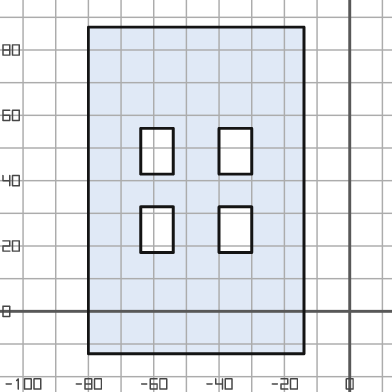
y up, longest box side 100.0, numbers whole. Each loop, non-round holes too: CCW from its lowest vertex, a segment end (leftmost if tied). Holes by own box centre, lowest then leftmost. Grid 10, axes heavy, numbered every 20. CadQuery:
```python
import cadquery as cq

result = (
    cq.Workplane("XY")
    .moveTo(-80.0, -13.0)
    .lineTo(-14.0, -13.0)
    .lineTo(-14.0, 87.0)
    .lineTo(-80.0, 87.0)
    .close()
    .moveTo(-64.0, 18.0)
    .lineTo(-54.0, 18.0)
    .lineTo(-54.0, 32.0)
    .lineTo(-64.0, 32.0)
    .close()
    .moveTo(-40.0, 18.0)
    .lineTo(-30.0, 18.0)
    .lineTo(-30.0, 32.0)
    .lineTo(-40.0, 32.0)
    .close()
    .moveTo(-64.0, 42.0)
    .lineTo(-54.0, 42.0)
    .lineTo(-54.0, 56.0)
    .lineTo(-64.0, 56.0)
    .close()
    .moveTo(-40.0, 42.0)
    .lineTo(-30.0, 42.0)
    .lineTo(-30.0, 56.0)
    .lineTo(-40.0, 56.0)
    .close()
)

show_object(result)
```